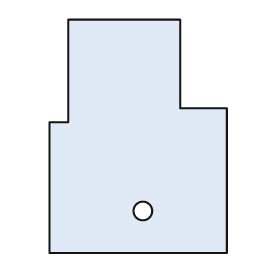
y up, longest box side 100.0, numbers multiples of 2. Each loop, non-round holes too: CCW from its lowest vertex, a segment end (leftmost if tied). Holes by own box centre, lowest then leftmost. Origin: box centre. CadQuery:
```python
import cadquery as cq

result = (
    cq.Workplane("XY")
    .moveTo(-38.0, -50.0)
    .lineTo(38.0, -50.0)
    .lineTo(38.0, 12.0)
    .lineTo(18.0, 12.0)
    .lineTo(18.0, 50.0)
    .lineTo(-30.0, 50.0)
    .lineTo(-30.0, 6.0)
    .lineTo(-38.0, 6.0)
    .close()
    .moveTo(2.0, -32.0)
    .circle(4.0)
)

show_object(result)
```